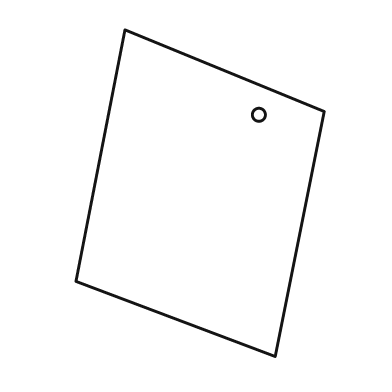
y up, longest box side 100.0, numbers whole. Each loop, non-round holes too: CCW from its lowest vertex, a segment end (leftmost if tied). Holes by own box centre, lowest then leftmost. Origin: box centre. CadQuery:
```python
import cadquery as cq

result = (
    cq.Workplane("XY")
    .moveTo(23.0, -50.0)
    .lineTo(38.0, 25.0)
    .lineTo(-23.0, 50.0)
    .lineTo(-38.0, -27.0)
    .close()
    .moveTo(18.0, 24.0)
    .circle(2.0)
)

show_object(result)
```